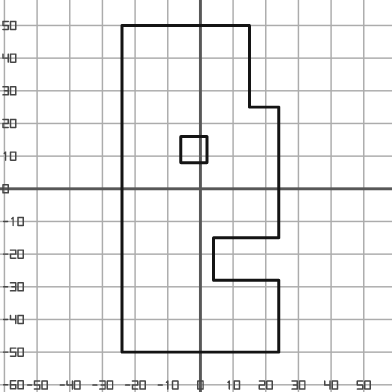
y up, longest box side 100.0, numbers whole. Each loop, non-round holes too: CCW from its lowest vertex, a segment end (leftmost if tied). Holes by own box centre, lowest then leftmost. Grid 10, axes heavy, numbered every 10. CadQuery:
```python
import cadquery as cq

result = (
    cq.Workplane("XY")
    .moveTo(-24.0, -50.0)
    .lineTo(24.0, -50.0)
    .lineTo(24.0, -28.0)
    .lineTo(4.0, -28.0)
    .lineTo(4.0, -15.0)
    .lineTo(24.0, -15.0)
    .lineTo(24.0, 25.0)
    .lineTo(15.0, 25.0)
    .lineTo(15.0, 50.0)
    .lineTo(-24.0, 50.0)
    .close()
    .moveTo(-6.0, 8.0)
    .lineTo(2.0, 8.0)
    .lineTo(2.0, 16.0)
    .lineTo(-6.0, 16.0)
    .close()
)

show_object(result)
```